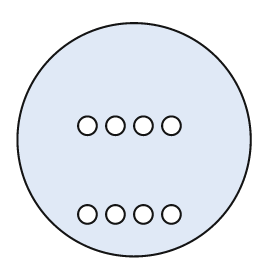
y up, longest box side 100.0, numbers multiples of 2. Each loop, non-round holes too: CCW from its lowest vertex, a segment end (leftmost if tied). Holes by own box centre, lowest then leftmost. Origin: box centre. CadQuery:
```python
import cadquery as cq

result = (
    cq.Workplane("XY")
    .moveTo(0.0, 0.0)
    .circle(50.0)
    .moveTo(-20.0, -32.0)
    .circle(4.0)
    .moveTo(-8.0, -32.0)
    .circle(4.0)
    .moveTo(4.0, -32.0)
    .circle(4.0)
    .moveTo(16.0, -32.0)
    .circle(4.0)
    .moveTo(-20.0, 6.0)
    .circle(4.0)
    .moveTo(-8.0, 6.0)
    .circle(4.0)
    .moveTo(4.0, 6.0)
    .circle(4.0)
    .moveTo(16.0, 6.0)
    .circle(4.0)
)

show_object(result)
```